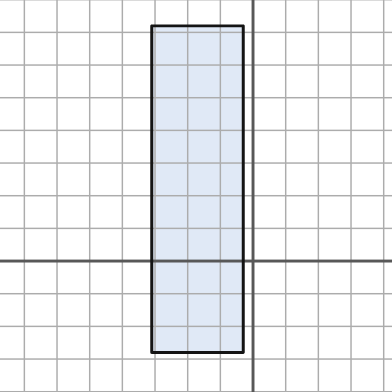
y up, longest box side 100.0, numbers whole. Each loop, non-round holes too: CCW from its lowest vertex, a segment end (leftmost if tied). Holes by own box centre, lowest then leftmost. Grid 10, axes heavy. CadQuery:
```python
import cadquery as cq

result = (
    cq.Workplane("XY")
    .moveTo(-31.0, -28.0)
    .lineTo(-3.0, -28.0)
    .lineTo(-3.0, 72.0)
    .lineTo(-31.0, 72.0)
    .close()
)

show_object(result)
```